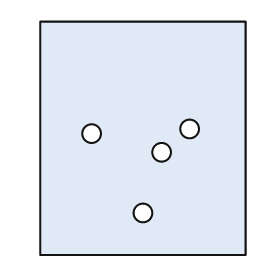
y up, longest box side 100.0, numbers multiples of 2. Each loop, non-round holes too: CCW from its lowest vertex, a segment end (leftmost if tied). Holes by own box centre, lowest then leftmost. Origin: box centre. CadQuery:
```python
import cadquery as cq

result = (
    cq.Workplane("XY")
    .moveTo(-44.0, -50.0)
    .lineTo(44.0, -50.0)
    .lineTo(44.0, 50.0)
    .lineTo(-44.0, 50.0)
    .close()
    .moveTo(0.0, -32.0)
    .circle(4.0)
    .moveTo(8.0, -6.0)
    .circle(4.0)
    .moveTo(-22.0, 2.0)
    .circle(4.0)
    .moveTo(20.0, 4.0)
    .circle(4.0)
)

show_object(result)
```